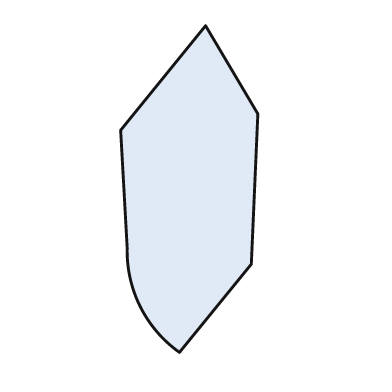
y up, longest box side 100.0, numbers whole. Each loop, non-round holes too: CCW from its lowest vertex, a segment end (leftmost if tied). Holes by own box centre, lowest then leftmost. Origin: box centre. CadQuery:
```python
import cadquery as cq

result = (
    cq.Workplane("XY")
    .moveTo(-3.0, -50.0)
    .lineTo(19.0, -23.0)
    .lineTo(21.0, 23.0)
    .lineTo(5.0, 50.0)
    .lineTo(-21.0, 18.0)
    .lineTo(-19.0, -18.0)
    .threePointArc((-15.0, -36.0), (-3.0, -50.0))
    .close()
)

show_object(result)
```